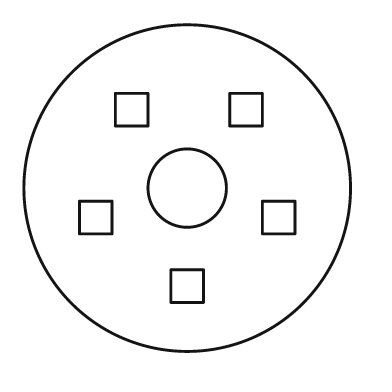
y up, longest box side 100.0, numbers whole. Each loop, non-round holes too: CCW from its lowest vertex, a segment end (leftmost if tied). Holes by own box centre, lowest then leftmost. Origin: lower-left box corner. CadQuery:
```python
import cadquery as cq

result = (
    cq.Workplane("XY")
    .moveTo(50.0, 50.0)
    .circle(50.0)
    .moveTo(45.0, 15.0)
    .lineTo(55.0, 15.0)
    .lineTo(55.0, 25.0)
    .lineTo(45.0, 25.0)
    .close()
    .moveTo(17.0, 36.0)
    .lineTo(27.0, 36.0)
    .lineTo(27.0, 46.0)
    .lineTo(17.0, 46.0)
    .close()
    .moveTo(73.0, 36.0)
    .lineTo(83.0, 36.0)
    .lineTo(83.0, 46.0)
    .lineTo(73.0, 46.0)
    .close()
    .moveTo(50.0, 50.0)
    .circle(12.0)
    .moveTo(28.0, 69.0)
    .lineTo(38.0, 69.0)
    .lineTo(38.0, 79.0)
    .lineTo(28.0, 79.0)
    .close()
    .moveTo(63.0, 69.0)
    .lineTo(73.0, 69.0)
    .lineTo(73.0, 79.0)
    .lineTo(63.0, 79.0)
    .close()
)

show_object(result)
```